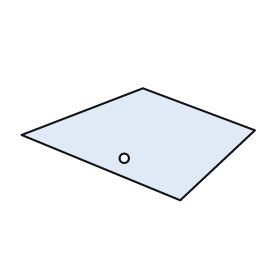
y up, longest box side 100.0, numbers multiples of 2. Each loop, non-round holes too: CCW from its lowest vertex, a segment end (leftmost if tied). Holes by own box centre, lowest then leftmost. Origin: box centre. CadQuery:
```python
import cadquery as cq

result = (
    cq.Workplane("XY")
    .moveTo(18.0, -24.0)
    .lineTo(50.0, 6.0)
    .lineTo(2.0, 24.0)
    .lineTo(-50.0, 4.0)
    .close()
    .moveTo(-6.0, -6.0)
    .circle(2.0)
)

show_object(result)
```